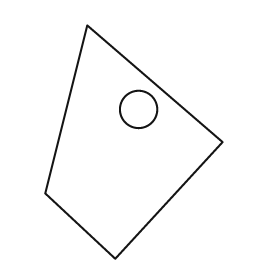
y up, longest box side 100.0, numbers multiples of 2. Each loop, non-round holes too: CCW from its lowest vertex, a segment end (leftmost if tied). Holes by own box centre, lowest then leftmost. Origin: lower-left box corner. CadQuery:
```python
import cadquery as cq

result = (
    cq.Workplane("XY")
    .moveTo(30.0, 0.0)
    .lineTo(76.0, 50.0)
    .lineTo(18.0, 100.0)
    .lineTo(0.0, 28.0)
    .close()
    .moveTo(40.0, 64.0)
    .circle(8.0)
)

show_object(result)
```